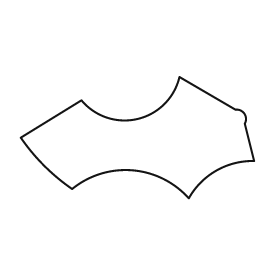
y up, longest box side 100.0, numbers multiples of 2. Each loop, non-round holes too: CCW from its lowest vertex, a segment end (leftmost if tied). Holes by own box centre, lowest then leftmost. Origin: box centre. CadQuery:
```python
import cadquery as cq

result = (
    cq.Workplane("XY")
    .moveTo(22.0, -26.0)
    .threePointArc((34.0, -14.0), (50.0, -10.0))
    .lineTo(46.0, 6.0)
    .threePointArc((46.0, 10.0), (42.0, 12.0))
    .lineTo(18.0, 26.0)
    .threePointArc((0.0, 8.0), (-24.0, 16.0))
    .lineTo(-50.0, 0.0)
    .threePointArc((-40.0, -12.0), (-28.0, -22.0))
    .threePointArc((-2.0, -14.0), (22.0, -26.0))
    .close()
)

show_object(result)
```